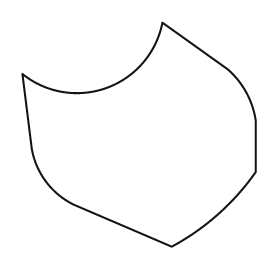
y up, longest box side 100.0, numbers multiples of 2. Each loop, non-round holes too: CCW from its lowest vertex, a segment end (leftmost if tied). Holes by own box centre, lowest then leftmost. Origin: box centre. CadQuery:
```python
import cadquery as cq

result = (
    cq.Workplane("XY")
    .moveTo(14.0, -48.0)
    .threePointArc((34.0, -34.0), (50.0, -16.0))
    .lineTo(50.0, 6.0)
    .threePointArc((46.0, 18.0), (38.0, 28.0))
    .lineTo(10.0, 48.0)
    .threePointArc((-14.0, 20.0), (-50.0, 26.0))
    .lineTo(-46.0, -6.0)
    .threePointArc((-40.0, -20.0), (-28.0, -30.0))
    .close()
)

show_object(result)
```